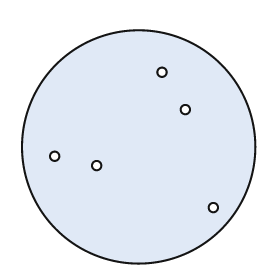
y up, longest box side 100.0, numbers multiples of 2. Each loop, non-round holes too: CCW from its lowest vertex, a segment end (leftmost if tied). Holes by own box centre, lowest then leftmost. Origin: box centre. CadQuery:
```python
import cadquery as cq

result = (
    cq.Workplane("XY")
    .moveTo(0.0, 0.0)
    .circle(50.0)
    .moveTo(32.0, -26.0)
    .circle(2.0)
    .moveTo(-18.0, -8.0)
    .circle(2.0)
    .moveTo(-36.0, -4.0)
    .circle(2.0)
    .moveTo(20.0, 16.0)
    .circle(2.0)
    .moveTo(10.0, 32.0)
    .circle(2.0)
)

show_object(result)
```